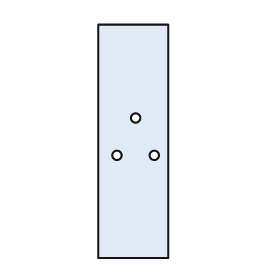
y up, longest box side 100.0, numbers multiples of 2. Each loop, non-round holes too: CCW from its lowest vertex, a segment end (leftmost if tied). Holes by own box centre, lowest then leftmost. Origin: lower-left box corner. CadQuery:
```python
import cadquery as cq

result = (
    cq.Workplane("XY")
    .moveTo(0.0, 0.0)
    .lineTo(30.0, 0.0)
    .lineTo(30.0, 100.0)
    .lineTo(0.0, 100.0)
    .close()
    .moveTo(8.0, 44.0)
    .circle(2.0)
    .moveTo(24.0, 44.0)
    .circle(2.0)
    .moveTo(16.0, 60.0)
    .circle(2.0)
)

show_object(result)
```